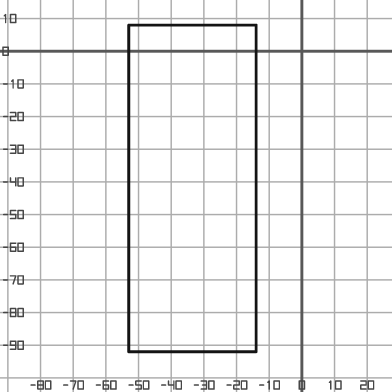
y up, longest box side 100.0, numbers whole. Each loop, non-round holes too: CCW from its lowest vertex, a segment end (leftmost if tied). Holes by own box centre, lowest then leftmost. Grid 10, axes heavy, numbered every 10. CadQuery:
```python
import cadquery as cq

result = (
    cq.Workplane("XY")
    .moveTo(-53.0, -92.0)
    .lineTo(-14.0, -92.0)
    .lineTo(-14.0, 8.0)
    .lineTo(-53.0, 8.0)
    .close()
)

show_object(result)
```